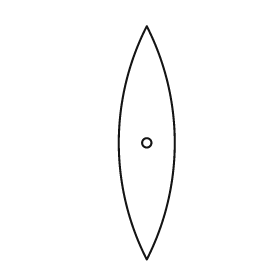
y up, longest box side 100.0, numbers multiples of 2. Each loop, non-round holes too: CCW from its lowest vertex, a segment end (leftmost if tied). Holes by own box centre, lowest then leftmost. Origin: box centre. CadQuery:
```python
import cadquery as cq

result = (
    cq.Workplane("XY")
    .moveTo(0.0, -50.0)
    .threePointArc((12.0, 0.0), (0.0, 50.0))
    .threePointArc((-12.0, 0.0), (0.0, -50.0))
    .close()
    .moveTo(0.0, 0.0)
    .circle(2.0)
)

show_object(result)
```